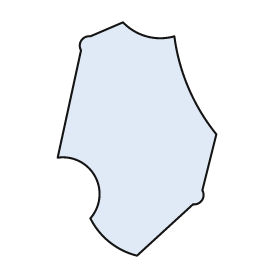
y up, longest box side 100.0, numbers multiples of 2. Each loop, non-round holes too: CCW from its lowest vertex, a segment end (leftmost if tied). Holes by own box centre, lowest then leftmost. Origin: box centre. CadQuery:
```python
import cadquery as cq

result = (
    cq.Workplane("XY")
    .moveTo(0.0, -50.0)
    .lineTo(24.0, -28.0)
    .threePointArc((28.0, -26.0), (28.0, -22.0))
    .lineTo(34.0, 2.0)
    .threePointArc((22.0, 22.0), (16.0, 44.0))
    .threePointArc((4.0, 44.0), (-6.0, 50.0))
    .lineTo(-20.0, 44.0)
    .threePointArc((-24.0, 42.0), (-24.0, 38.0))
    .lineTo(-34.0, -8.0)
    .threePointArc((-18.0, -16.0), (-20.0, -34.0))
    .threePointArc((-12.0, -44.0), (0.0, -50.0))
    .close()
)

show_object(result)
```